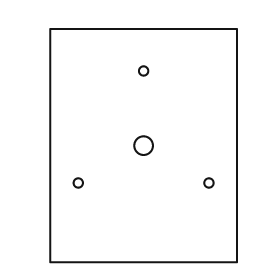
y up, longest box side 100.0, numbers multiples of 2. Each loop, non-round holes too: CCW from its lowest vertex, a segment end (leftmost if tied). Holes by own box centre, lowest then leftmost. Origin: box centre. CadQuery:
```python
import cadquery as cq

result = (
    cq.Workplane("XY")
    .moveTo(-40.0, -50.0)
    .lineTo(40.0, -50.0)
    .lineTo(40.0, 50.0)
    .lineTo(-40.0, 50.0)
    .close()
    .moveTo(-28.0, -16.0)
    .circle(2.0)
    .moveTo(28.0, -16.0)
    .circle(2.0)
    .moveTo(0.0, 0.0)
    .circle(4.0)
    .moveTo(0.0, 32.0)
    .circle(2.0)
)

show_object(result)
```